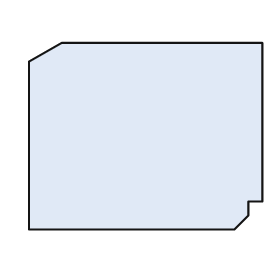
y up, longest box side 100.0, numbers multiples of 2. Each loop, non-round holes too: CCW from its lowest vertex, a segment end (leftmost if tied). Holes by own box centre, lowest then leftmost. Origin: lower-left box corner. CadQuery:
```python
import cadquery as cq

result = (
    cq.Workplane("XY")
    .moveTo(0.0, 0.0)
    .lineTo(88.0, 0.0)
    .lineTo(94.0, 6.0)
    .lineTo(94.0, 12.0)
    .lineTo(100.0, 12.0)
    .lineTo(100.0, 80.0)
    .lineTo(14.0, 80.0)
    .lineTo(0.0, 72.0)
    .close()
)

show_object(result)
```